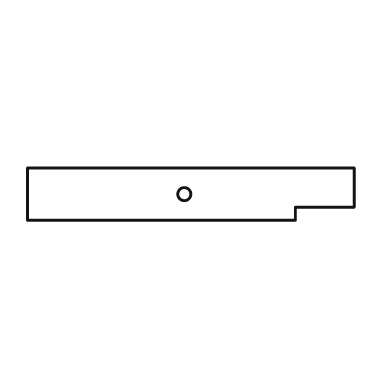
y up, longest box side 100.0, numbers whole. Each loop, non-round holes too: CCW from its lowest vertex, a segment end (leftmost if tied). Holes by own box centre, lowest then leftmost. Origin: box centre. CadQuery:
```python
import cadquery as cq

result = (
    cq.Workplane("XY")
    .moveTo(-50.0, -8.0)
    .lineTo(32.0, -8.0)
    .lineTo(32.0, -4.0)
    .lineTo(50.0, -4.0)
    .lineTo(50.0, 8.0)
    .lineTo(-50.0, 8.0)
    .close()
    .moveTo(-2.0, 0.0)
    .circle(2.0)
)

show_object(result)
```